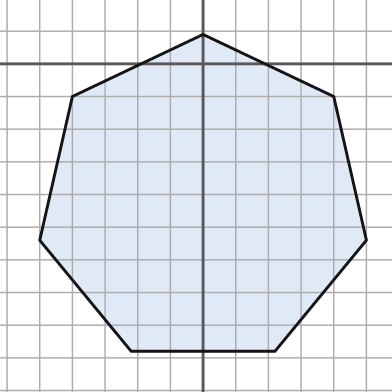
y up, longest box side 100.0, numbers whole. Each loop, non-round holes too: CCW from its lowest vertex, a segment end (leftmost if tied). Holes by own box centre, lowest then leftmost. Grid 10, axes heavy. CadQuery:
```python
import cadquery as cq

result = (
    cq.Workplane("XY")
    .moveTo(-22.0, -88.0)
    .lineTo(22.0, -88.0)
    .lineTo(50.0, -54.0)
    .lineTo(40.0, -10.0)
    .lineTo(0.0, 9.0)
    .lineTo(-40.0, -10.0)
    .lineTo(-50.0, -54.0)
    .close()
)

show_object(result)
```